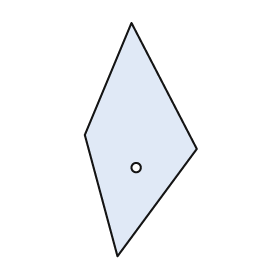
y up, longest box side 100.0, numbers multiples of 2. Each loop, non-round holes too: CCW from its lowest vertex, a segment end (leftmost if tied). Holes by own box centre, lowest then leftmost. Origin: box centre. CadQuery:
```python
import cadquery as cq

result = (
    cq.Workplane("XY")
    .moveTo(-10.0, -50.0)
    .lineTo(24.0, -4.0)
    .lineTo(-4.0, 50.0)
    .lineTo(-24.0, 2.0)
    .close()
    .moveTo(-2.0, -12.0)
    .circle(2.0)
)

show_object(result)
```